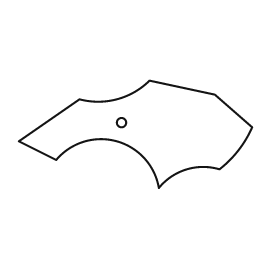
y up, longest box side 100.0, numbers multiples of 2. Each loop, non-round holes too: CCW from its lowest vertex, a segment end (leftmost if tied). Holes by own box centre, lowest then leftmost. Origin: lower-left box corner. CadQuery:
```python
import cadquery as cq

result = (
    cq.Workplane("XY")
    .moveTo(60.0, 0.0)
    .threePointArc((72.0, 8.0), (86.0, 8.0))
    .threePointArc((94.0, 16.0), (100.0, 26.0))
    .lineTo(84.0, 40.0)
    .lineTo(56.0, 46.0)
    .threePointArc((42.0, 38.0), (26.0, 38.0))
    .lineTo(0.0, 20.0)
    .lineTo(16.0, 12.0)
    .threePointArc((42.0, 20.0), (60.0, 0.0))
    .close()
    .moveTo(44.0, 28.0)
    .circle(2.0)
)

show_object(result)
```